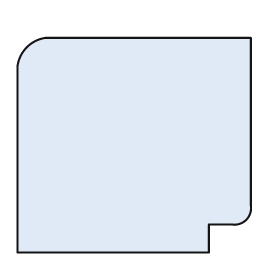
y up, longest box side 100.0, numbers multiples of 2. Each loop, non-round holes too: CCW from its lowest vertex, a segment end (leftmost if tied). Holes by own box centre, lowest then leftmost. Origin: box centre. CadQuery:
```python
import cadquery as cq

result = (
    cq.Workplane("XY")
    .moveTo(-50.0, -46.0)
    .lineTo(32.0, -46.0)
    .lineTo(32.0, -34.0)
    .lineTo(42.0, -34.0)
    .threePointArc((48.0, -32.0), (50.0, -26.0))
    .lineTo(50.0, 46.0)
    .lineTo(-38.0, 46.0)
    .threePointArc((-46.0, 42.0), (-50.0, 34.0))
    .close()
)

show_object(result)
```